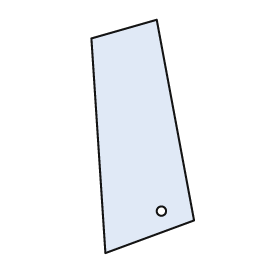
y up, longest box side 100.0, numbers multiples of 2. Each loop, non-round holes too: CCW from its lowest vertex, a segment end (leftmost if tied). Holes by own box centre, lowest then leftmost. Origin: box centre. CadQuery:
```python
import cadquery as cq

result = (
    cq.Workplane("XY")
    .moveTo(-16.0, -50.0)
    .lineTo(22.0, -36.0)
    .lineTo(6.0, 50.0)
    .lineTo(-22.0, 42.0)
    .close()
    .moveTo(8.0, -32.0)
    .circle(2.0)
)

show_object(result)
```